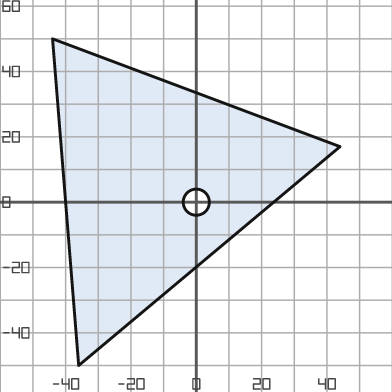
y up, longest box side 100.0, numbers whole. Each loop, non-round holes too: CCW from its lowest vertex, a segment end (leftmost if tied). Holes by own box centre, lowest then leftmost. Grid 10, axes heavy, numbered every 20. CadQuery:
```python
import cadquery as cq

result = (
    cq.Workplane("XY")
    .moveTo(-36.0, -50.0)
    .lineTo(44.0, 17.0)
    .lineTo(-44.0, 50.0)
    .close()
    .moveTo(0.0, 0.0)
    .circle(4.0)
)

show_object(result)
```